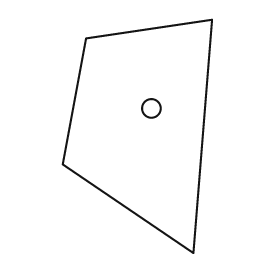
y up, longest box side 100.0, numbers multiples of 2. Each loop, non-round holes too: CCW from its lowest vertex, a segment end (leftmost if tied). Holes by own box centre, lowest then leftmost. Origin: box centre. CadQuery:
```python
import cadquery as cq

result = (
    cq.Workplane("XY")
    .moveTo(24.0, -50.0)
    .lineTo(32.0, 50.0)
    .lineTo(-22.0, 42.0)
    .lineTo(-32.0, -12.0)
    .close()
    .moveTo(6.0, 12.0)
    .circle(4.0)
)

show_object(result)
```